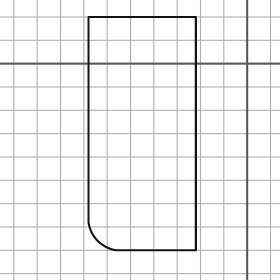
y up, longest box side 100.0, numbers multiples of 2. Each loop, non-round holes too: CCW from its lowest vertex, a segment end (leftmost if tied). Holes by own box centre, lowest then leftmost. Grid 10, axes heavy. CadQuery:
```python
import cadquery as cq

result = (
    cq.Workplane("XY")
    .moveTo(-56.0, -80.0)
    .lineTo(-22.0, -80.0)
    .lineTo(-22.0, 20.0)
    .lineTo(-68.0, 20.0)
    .lineTo(-68.0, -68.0)
    .threePointArc((-64.0, -76.0), (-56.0, -80.0))
    .close()
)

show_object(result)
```